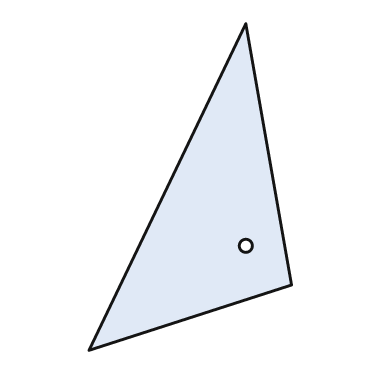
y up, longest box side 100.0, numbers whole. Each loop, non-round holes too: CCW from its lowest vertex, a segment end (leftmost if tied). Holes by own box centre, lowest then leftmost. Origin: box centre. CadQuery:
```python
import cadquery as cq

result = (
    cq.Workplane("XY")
    .moveTo(-31.0, -50.0)
    .lineTo(31.0, -30.0)
    .lineTo(17.0, 50.0)
    .close()
    .moveTo(17.0, -18.0)
    .circle(2.0)
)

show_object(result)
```